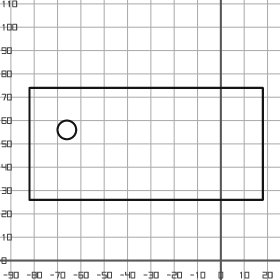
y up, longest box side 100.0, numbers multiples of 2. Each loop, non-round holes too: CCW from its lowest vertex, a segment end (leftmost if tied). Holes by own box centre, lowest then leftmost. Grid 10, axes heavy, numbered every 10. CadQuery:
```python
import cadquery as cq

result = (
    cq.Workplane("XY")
    .moveTo(-82.0, 26.0)
    .lineTo(18.0, 26.0)
    .lineTo(18.0, 74.0)
    .lineTo(-82.0, 74.0)
    .close()
    .moveTo(-66.0, 56.0)
    .circle(4.0)
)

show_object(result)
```